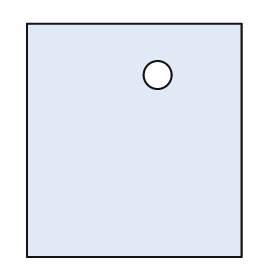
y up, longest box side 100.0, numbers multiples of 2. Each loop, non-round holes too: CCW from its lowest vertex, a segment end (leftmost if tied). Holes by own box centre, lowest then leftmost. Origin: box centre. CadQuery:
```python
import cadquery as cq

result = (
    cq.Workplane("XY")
    .moveTo(-46.0, -50.0)
    .lineTo(46.0, -50.0)
    .lineTo(46.0, 50.0)
    .lineTo(-46.0, 50.0)
    .close()
    .moveTo(10.0, 28.0)
    .circle(6.0)
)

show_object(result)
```